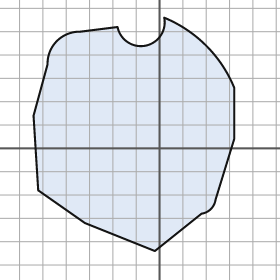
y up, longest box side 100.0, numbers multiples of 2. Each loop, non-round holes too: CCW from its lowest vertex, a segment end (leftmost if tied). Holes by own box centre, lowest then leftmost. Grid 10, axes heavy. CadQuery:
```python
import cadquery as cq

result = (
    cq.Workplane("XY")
    .moveTo(-2.0, -44.0)
    .lineTo(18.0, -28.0)
    .threePointArc((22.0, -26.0), (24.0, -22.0))
    .lineTo(32.0, 4.0)
    .lineTo(32.0, 26.0)
    .threePointArc((20.0, 44.0), (2.0, 56.0))
    .threePointArc((-6.0, 44.0), (-18.0, 52.0))
    .lineTo(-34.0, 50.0)
    .threePointArc((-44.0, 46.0), (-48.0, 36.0))
    .lineTo(-54.0, 14.0)
    .lineTo(-52.0, -18.0)
    .lineTo(-32.0, -32.0)
    .close()
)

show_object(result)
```